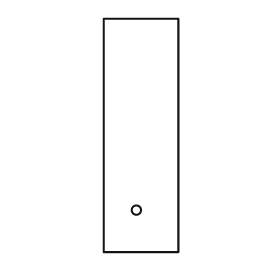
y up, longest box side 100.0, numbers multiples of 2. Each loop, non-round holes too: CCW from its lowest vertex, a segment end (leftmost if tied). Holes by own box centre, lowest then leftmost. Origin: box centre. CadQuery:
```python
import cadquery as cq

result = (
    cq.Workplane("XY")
    .moveTo(-16.0, -50.0)
    .lineTo(16.0, -50.0)
    .lineTo(16.0, 50.0)
    .lineTo(-16.0, 50.0)
    .close()
    .moveTo(-2.0, -32.0)
    .circle(2.0)
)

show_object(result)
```